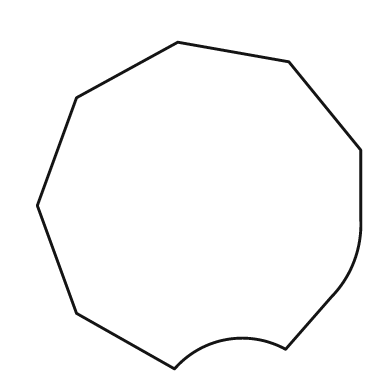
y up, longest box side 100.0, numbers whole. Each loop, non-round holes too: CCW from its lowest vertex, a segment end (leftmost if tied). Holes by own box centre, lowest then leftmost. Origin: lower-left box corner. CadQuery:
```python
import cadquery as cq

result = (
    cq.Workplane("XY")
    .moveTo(42.0, 0.0)
    .threePointArc((58.0, 9.0), (76.0, 6.0))
    .lineTo(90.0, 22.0)
    .threePointArc((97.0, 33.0), (99.0, 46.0))
    .lineTo(99.0, 67.0)
    .lineTo(77.0, 94.0)
    .lineTo(43.0, 100.0)
    .lineTo(12.0, 83.0)
    .lineTo(0.0, 50.0)
    .lineTo(12.0, 17.0)
    .close()
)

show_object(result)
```